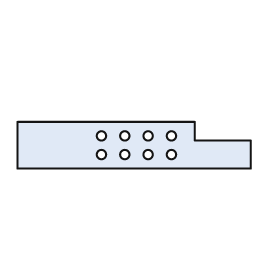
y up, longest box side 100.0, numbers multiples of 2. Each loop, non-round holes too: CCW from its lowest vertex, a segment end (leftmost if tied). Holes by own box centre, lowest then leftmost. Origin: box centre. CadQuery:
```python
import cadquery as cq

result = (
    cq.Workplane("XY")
    .moveTo(-50.0, -10.0)
    .lineTo(50.0, -10.0)
    .lineTo(50.0, 2.0)
    .lineTo(26.0, 2.0)
    .lineTo(26.0, 10.0)
    .lineTo(-50.0, 10.0)
    .close()
    .moveTo(-14.0, -4.0)
    .circle(2.0)
    .moveTo(-4.0, -4.0)
    .circle(2.0)
    .moveTo(6.0, -4.0)
    .circle(2.0)
    .moveTo(16.0, -4.0)
    .circle(2.0)
    .moveTo(-14.0, 4.0)
    .circle(2.0)
    .moveTo(-4.0, 4.0)
    .circle(2.0)
    .moveTo(6.0, 4.0)
    .circle(2.0)
    .moveTo(16.0, 4.0)
    .circle(2.0)
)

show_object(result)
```